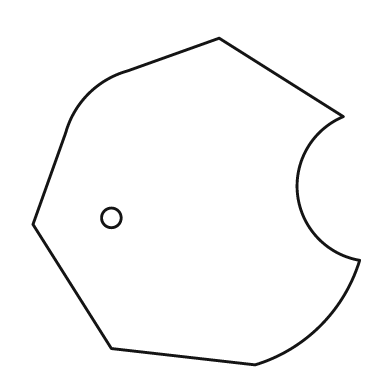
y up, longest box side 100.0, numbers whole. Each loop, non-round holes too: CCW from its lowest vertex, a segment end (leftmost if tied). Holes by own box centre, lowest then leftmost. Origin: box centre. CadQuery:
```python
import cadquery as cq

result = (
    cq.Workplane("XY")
    .moveTo(18.0, -50.0)
    .threePointArc((38.0, -38.0), (50.0, -18.0))
    .threePointArc((31.0, 2.0), (45.0, 26.0))
    .lineTo(7.0, 50.0)
    .lineTo(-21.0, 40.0)
    .threePointArc((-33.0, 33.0), (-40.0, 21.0))
    .lineTo(-50.0, -7.0)
    .lineTo(-26.0, -45.0)
    .close()
    .moveTo(-26.0, -5.0)
    .circle(3.0)
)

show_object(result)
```